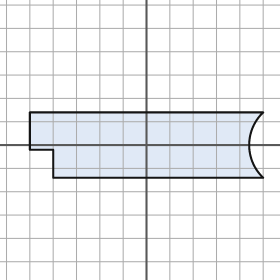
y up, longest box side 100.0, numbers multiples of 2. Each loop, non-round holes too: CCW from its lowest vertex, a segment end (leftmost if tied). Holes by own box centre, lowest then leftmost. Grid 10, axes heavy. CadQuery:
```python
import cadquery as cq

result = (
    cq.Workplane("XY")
    .moveTo(-40.0, -14.0)
    .lineTo(50.0, -14.0)
    .threePointArc((44.0, 0.0), (50.0, 14.0))
    .lineTo(-50.0, 14.0)
    .lineTo(-50.0, -2.0)
    .lineTo(-40.0, -2.0)
    .close()
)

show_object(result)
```